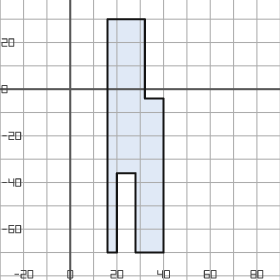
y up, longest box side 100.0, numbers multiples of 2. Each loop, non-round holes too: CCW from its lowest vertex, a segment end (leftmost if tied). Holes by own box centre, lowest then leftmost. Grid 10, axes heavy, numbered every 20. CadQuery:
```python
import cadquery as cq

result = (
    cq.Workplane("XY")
    .moveTo(16.0, -70.0)
    .lineTo(20.0, -70.0)
    .lineTo(20.0, -36.0)
    .lineTo(28.0, -36.0)
    .lineTo(28.0, -70.0)
    .lineTo(40.0, -70.0)
    .lineTo(40.0, -4.0)
    .lineTo(32.0, -4.0)
    .lineTo(32.0, 30.0)
    .lineTo(16.0, 30.0)
    .close()
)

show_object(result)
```